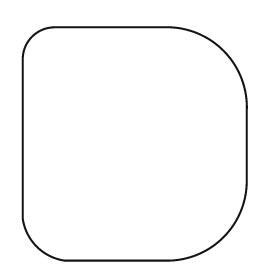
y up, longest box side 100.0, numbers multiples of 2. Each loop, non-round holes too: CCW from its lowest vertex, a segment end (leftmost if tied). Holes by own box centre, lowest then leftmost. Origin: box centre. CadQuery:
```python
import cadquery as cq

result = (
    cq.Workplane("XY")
    .moveTo(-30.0, -50.0)
    .lineTo(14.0, -50.0)
    .threePointArc((38.0, -40.0), (48.0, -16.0))
    .lineTo(48.0, 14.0)
    .threePointArc((38.0, 40.0), (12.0, 50.0))
    .lineTo(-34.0, 50.0)
    .threePointArc((-44.0, 46.0), (-48.0, 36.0))
    .lineTo(-48.0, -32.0)
    .threePointArc((-42.0, -44.0), (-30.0, -50.0))
    .close()
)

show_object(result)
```